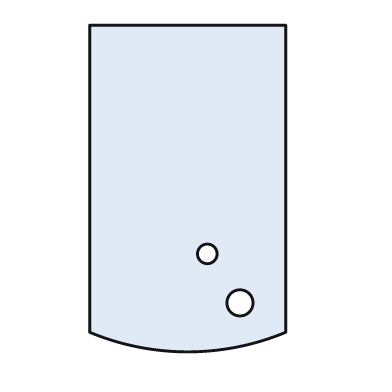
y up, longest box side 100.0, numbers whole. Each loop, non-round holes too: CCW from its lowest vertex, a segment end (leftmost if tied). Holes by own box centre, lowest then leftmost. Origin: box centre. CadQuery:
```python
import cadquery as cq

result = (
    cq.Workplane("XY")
    .moveTo(-30.0, -44.0)
    .threePointArc((0.0, -50.0), (30.0, -44.0))
    .lineTo(30.0, 50.0)
    .lineTo(-30.0, 50.0)
    .close()
    .moveTo(16.0, -35.0)
    .circle(4.0)
    .moveTo(6.0, -20.0)
    .circle(3.0)
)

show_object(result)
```